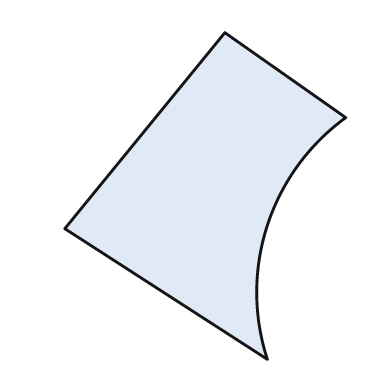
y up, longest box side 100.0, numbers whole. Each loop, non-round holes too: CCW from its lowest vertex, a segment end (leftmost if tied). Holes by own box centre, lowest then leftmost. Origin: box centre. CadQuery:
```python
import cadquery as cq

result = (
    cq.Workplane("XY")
    .moveTo(19.0, -50.0)
    .threePointArc((19.0, -9.0), (43.0, 24.0))
    .lineTo(6.0, 50.0)
    .lineTo(-43.0, -10.0)
    .close()
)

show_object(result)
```